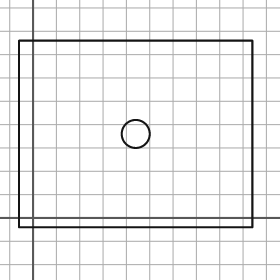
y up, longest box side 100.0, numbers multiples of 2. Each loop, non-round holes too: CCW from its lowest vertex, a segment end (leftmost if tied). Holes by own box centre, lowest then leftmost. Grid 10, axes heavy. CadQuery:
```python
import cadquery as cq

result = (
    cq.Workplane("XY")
    .moveTo(-6.0, -4.0)
    .lineTo(94.0, -4.0)
    .lineTo(94.0, 76.0)
    .lineTo(-6.0, 76.0)
    .close()
    .moveTo(44.0, 36.0)
    .circle(6.0)
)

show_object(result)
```